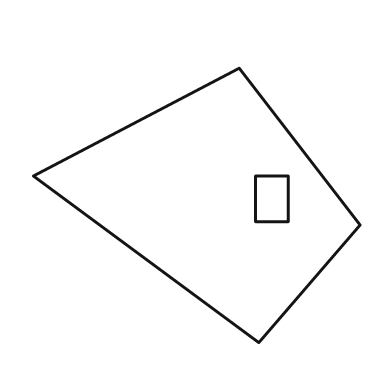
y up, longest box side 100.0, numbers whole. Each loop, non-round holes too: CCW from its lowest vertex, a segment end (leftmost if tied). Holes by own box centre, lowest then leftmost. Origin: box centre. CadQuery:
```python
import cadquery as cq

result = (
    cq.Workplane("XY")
    .moveTo(19.0, -42.0)
    .lineTo(50.0, -6.0)
    .lineTo(13.0, 42.0)
    .lineTo(-50.0, 9.0)
    .close()
    .moveTo(18.0, -5.0)
    .lineTo(28.0, -5.0)
    .lineTo(28.0, 9.0)
    .lineTo(18.0, 9.0)
    .close()
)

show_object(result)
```